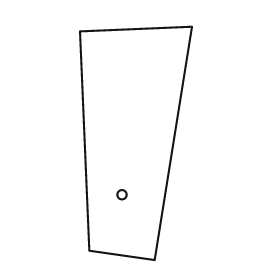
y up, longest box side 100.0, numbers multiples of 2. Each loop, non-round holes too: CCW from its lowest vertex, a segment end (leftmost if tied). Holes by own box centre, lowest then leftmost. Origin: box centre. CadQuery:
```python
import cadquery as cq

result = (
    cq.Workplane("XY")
    .moveTo(8.0, -50.0)
    .lineTo(24.0, 50.0)
    .lineTo(-24.0, 48.0)
    .lineTo(-20.0, -46.0)
    .close()
    .moveTo(-6.0, -22.0)
    .circle(2.0)
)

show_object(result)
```